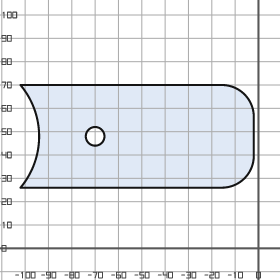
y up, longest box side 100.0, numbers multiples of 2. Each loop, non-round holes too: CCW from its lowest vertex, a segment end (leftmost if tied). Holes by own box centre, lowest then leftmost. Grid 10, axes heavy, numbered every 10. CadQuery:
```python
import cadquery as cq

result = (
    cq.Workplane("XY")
    .moveTo(-102.0, 26.0)
    .lineTo(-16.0, 26.0)
    .threePointArc((-6.0, 30.0), (-2.0, 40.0))
    .lineTo(-2.0, 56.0)
    .threePointArc((-6.0, 66.0), (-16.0, 70.0))
    .lineTo(-102.0, 70.0)
    .threePointArc((-94.0, 48.0), (-102.0, 26.0))
    .close()
    .moveTo(-70.0, 48.0)
    .circle(4.0)
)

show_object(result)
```